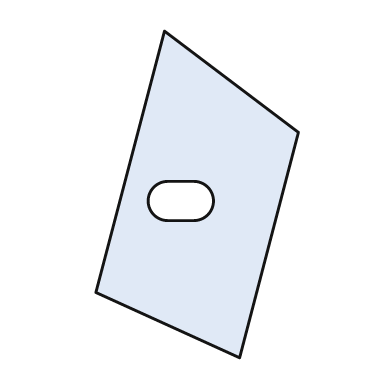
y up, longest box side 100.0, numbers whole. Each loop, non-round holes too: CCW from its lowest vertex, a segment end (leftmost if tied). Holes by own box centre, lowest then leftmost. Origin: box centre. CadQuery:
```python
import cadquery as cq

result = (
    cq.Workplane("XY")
    .moveTo(13.0, -50.0)
    .lineTo(31.0, 19.0)
    .lineTo(-10.0, 50.0)
    .lineTo(-31.0, -30.0)
    .close()
    .moveTo(-9.0, -8.0)
    .lineTo(-1.0, -8.0)
    .threePointArc((5.0, -2.0), (-1.0, 4.0))
    .lineTo(-9.0, 4.0)
    .threePointArc((-15.0, -2.0), (-9.0, -8.0))
    .close()
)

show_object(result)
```